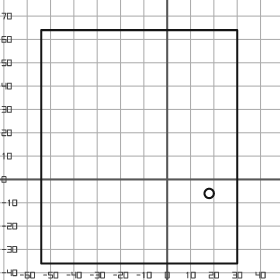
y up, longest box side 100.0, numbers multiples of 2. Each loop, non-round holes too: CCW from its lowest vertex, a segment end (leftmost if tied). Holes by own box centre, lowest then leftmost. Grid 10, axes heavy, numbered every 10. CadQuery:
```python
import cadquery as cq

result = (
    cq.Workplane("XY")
    .moveTo(-54.0, -36.0)
    .lineTo(30.0, -36.0)
    .lineTo(30.0, 64.0)
    .lineTo(-54.0, 64.0)
    .close()
    .moveTo(18.0, -6.0)
    .circle(2.0)
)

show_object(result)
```